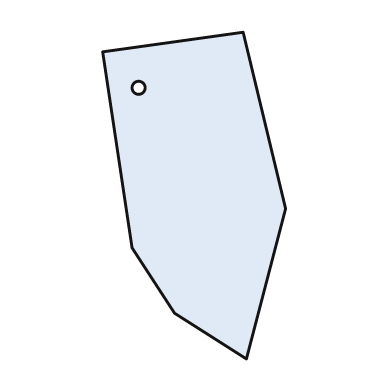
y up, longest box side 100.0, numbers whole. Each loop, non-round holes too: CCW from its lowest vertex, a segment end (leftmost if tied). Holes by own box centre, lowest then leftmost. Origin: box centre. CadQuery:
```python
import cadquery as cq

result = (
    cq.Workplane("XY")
    .moveTo(16.0, -50.0)
    .lineTo(28.0, -4.0)
    .lineTo(15.0, 50.0)
    .lineTo(-28.0, 44.0)
    .lineTo(-19.0, -16.0)
    .lineTo(-6.0, -36.0)
    .close()
    .moveTo(-17.0, 33.0)
    .circle(2.0)
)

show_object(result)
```